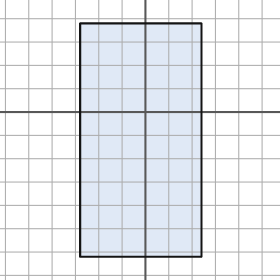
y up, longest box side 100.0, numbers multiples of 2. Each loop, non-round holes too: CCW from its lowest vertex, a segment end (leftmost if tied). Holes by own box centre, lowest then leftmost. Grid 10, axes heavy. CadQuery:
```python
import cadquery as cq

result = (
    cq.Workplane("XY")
    .moveTo(-28.0, -62.0)
    .lineTo(24.0, -62.0)
    .lineTo(24.0, 38.0)
    .lineTo(-28.0, 38.0)
    .close()
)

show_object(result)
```